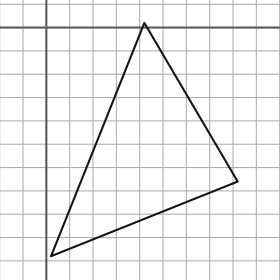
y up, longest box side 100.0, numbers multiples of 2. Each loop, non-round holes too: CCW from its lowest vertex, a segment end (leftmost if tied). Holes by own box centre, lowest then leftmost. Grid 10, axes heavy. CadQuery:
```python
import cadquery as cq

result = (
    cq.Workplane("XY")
    .moveTo(2.0, -98.0)
    .lineTo(82.0, -66.0)
    .lineTo(42.0, 2.0)
    .close()
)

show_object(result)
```